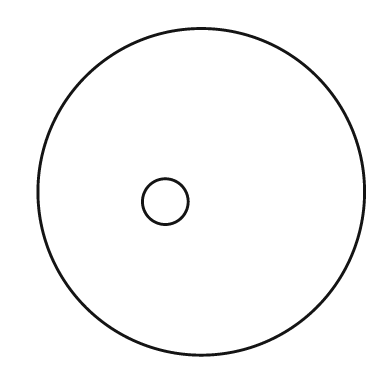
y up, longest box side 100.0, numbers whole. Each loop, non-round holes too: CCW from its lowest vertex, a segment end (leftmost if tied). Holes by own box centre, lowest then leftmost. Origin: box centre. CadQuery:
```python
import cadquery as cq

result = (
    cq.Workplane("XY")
    .moveTo(0.0, 0.0)
    .circle(50.0)
    .moveTo(-11.0, -3.0)
    .circle(7.0)
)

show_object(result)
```